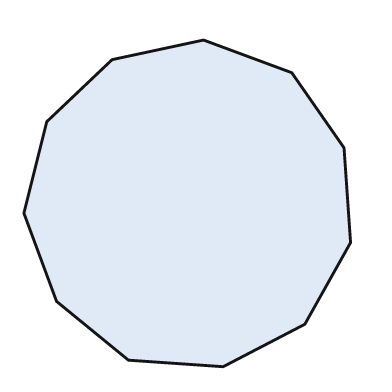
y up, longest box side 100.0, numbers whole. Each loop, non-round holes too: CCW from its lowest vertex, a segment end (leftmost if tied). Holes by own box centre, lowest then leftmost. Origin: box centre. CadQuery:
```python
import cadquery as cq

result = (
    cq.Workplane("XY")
    .moveTo(11.0, -50.0)
    .lineTo(36.0, -37.0)
    .lineTo(50.0, -12.0)
    .lineTo(48.0, 17.0)
    .lineTo(32.0, 40.0)
    .lineTo(5.0, 50.0)
    .lineTo(-23.0, 44.0)
    .lineTo(-43.0, 25.0)
    .lineTo(-50.0, -3.0)
    .lineTo(-40.0, -30.0)
    .lineTo(-18.0, -48.0)
    .close()
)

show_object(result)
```